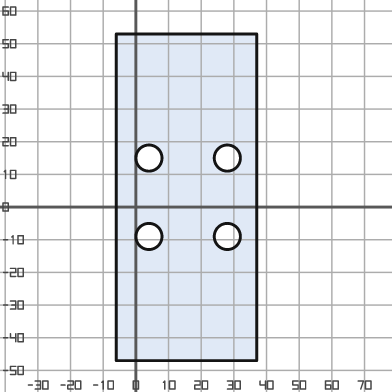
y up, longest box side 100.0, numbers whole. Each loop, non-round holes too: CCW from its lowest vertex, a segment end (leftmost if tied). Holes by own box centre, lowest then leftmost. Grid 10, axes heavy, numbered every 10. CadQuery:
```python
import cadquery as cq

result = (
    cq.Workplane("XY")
    .moveTo(-6.0, -47.0)
    .lineTo(37.0, -47.0)
    .lineTo(37.0, 53.0)
    .lineTo(-6.0, 53.0)
    .close()
    .moveTo(4.0, -9.0)
    .circle(4.0)
    .moveTo(28.0, -9.0)
    .circle(4.0)
    .moveTo(4.0, 15.0)
    .circle(4.0)
    .moveTo(28.0, 15.0)
    .circle(4.0)
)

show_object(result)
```